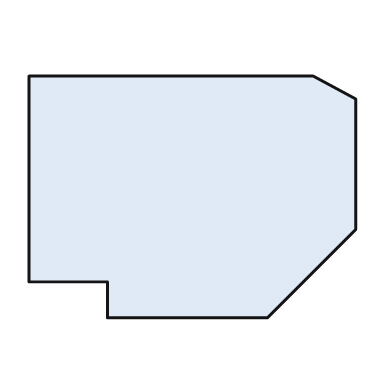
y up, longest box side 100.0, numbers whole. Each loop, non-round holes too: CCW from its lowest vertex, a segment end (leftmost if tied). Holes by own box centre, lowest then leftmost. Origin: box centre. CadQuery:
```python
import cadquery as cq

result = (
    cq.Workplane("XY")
    .moveTo(-26.0, -37.0)
    .lineTo(23.0, -37.0)
    .lineTo(50.0, -10.0)
    .lineTo(50.0, 30.0)
    .lineTo(37.0, 37.0)
    .lineTo(-50.0, 37.0)
    .lineTo(-50.0, -26.0)
    .lineTo(-26.0, -26.0)
    .close()
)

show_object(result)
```